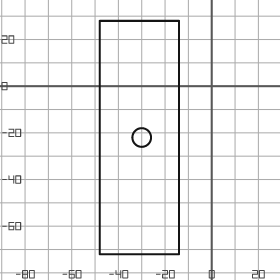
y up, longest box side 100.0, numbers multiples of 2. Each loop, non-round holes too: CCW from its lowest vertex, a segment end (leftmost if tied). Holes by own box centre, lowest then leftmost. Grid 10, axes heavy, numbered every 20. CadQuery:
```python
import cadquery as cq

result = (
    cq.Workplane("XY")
    .moveTo(-48.0, -72.0)
    .lineTo(-14.0, -72.0)
    .lineTo(-14.0, 28.0)
    .lineTo(-48.0, 28.0)
    .close()
    .moveTo(-30.0, -22.0)
    .circle(4.0)
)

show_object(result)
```